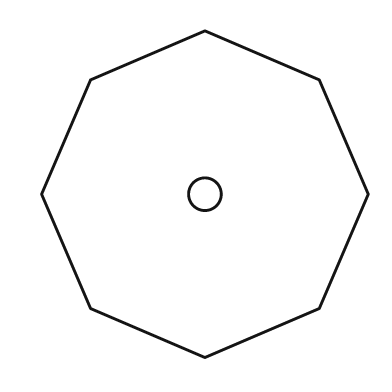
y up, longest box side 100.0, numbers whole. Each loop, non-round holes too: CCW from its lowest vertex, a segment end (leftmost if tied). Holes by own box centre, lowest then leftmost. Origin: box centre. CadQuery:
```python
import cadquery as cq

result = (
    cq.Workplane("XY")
    .moveTo(0.0, -50.0)
    .lineTo(35.0, -35.0)
    .lineTo(50.0, 0.0)
    .lineTo(35.0, 35.0)
    .lineTo(0.0, 50.0)
    .lineTo(-35.0, 35.0)
    .lineTo(-50.0, 0.0)
    .lineTo(-35.0, -35.0)
    .close()
    .moveTo(0.0, 0.0)
    .circle(5.0)
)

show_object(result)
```